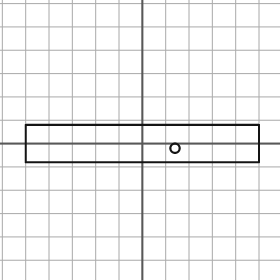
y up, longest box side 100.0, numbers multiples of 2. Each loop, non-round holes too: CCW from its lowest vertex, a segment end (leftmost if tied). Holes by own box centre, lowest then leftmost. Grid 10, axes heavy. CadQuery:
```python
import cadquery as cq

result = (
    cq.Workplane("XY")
    .moveTo(-50.0, -8.0)
    .lineTo(50.0, -8.0)
    .lineTo(50.0, 8.0)
    .lineTo(-50.0, 8.0)
    .close()
    .moveTo(14.0, -2.0)
    .circle(2.0)
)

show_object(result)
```